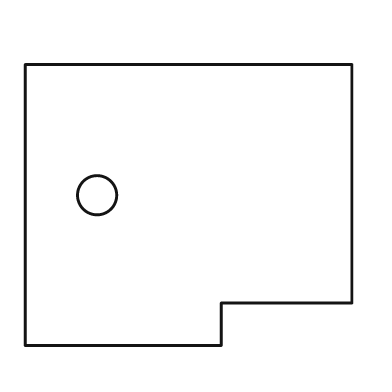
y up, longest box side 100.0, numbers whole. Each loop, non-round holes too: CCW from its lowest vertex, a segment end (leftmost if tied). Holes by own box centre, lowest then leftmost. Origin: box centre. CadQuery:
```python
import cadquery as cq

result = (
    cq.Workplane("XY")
    .moveTo(-50.0, -43.0)
    .lineTo(10.0, -43.0)
    .lineTo(10.0, -30.0)
    .lineTo(50.0, -30.0)
    .lineTo(50.0, 43.0)
    .lineTo(-50.0, 43.0)
    .close()
    .moveTo(-28.0, 3.0)
    .circle(6.0)
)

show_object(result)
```